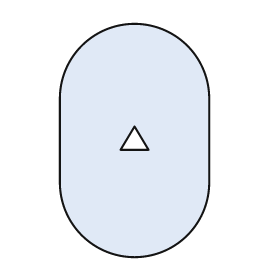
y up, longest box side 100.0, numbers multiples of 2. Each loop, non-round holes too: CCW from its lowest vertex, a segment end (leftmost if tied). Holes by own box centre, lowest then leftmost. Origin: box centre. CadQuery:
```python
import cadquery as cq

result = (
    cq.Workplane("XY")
    .moveTo(-32.0, -18.0)
    .threePointArc((0.0, -50.0), (32.0, -18.0))
    .lineTo(32.0, 18.0)
    .threePointArc((0.0, 50.0), (-32.0, 18.0))
    .close()
    .moveTo(-6.0, -4.0)
    .lineTo(6.0, -4.0)
    .lineTo(0.0, 6.0)
    .close()
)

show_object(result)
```